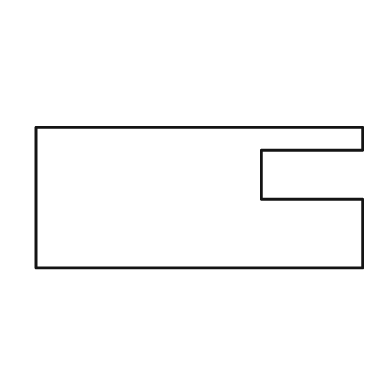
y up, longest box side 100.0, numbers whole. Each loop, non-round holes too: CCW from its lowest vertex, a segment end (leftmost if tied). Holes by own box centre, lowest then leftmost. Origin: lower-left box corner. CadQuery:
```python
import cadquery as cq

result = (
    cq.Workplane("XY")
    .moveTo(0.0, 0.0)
    .lineTo(100.0, 0.0)
    .lineTo(100.0, 21.0)
    .lineTo(69.0, 21.0)
    .lineTo(69.0, 36.0)
    .lineTo(100.0, 36.0)
    .lineTo(100.0, 43.0)
    .lineTo(0.0, 43.0)
    .close()
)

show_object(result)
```